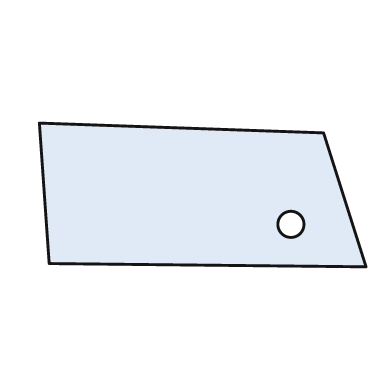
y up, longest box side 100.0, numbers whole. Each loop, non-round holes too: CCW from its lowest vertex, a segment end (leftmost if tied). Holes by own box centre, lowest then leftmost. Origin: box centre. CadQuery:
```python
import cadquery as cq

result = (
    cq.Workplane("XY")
    .moveTo(50.0, -22.0)
    .lineTo(37.0, 19.0)
    .lineTo(-50.0, 22.0)
    .lineTo(-47.0, -21.0)
    .close()
    .moveTo(27.0, -9.0)
    .circle(4.0)
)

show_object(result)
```